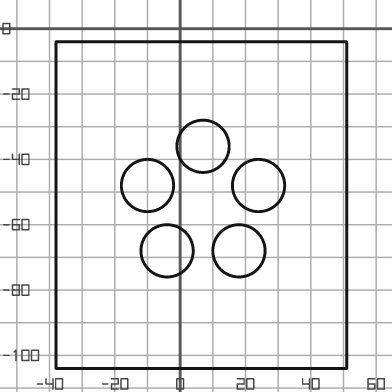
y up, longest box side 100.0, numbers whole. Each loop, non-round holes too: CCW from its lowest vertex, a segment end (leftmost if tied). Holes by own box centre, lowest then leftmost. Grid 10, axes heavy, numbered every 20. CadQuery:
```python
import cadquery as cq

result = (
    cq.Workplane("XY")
    .moveTo(-38.0, -104.0)
    .lineTo(51.0, -104.0)
    .lineTo(51.0, -4.0)
    .lineTo(-38.0, -4.0)
    .close()
    .moveTo(-4.0, -68.0)
    .circle(8.0)
    .moveTo(18.0, -68.0)
    .circle(8.0)
    .moveTo(-10.0, -48.0)
    .circle(8.0)
    .moveTo(24.0, -48.0)
    .circle(8.0)
    .moveTo(7.0, -36.0)
    .circle(8.0)
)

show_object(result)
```